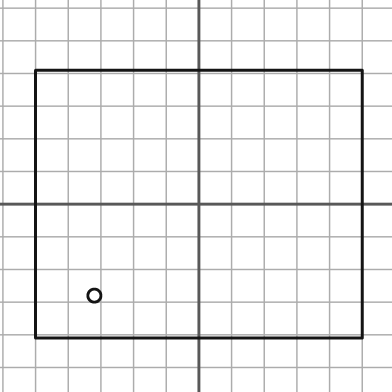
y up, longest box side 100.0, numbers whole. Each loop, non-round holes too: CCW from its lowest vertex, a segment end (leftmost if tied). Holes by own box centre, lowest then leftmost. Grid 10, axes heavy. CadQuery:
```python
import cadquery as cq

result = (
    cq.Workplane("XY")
    .moveTo(-50.0, -41.0)
    .lineTo(50.0, -41.0)
    .lineTo(50.0, 41.0)
    .lineTo(-50.0, 41.0)
    .close()
    .moveTo(-32.0, -28.0)
    .circle(2.0)
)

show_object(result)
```